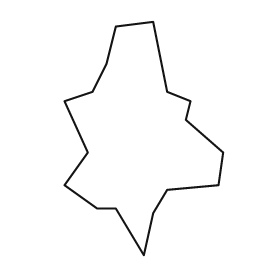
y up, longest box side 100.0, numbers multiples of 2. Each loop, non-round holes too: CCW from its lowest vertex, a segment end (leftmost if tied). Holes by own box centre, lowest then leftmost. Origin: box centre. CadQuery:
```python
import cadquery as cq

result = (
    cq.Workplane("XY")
    .moveTo(0.0, -50.0)
    .lineTo(4.0, -32.0)
    .lineTo(10.0, -22.0)
    .lineTo(32.0, -20.0)
    .lineTo(34.0, -6.0)
    .lineTo(18.0, 8.0)
    .lineTo(20.0, 16.0)
    .lineTo(10.0, 20.0)
    .lineTo(4.0, 50.0)
    .lineTo(-12.0, 48.0)
    .lineTo(-16.0, 32.0)
    .lineTo(-22.0, 20.0)
    .lineTo(-34.0, 16.0)
    .lineTo(-24.0, -6.0)
    .lineTo(-34.0, -20.0)
    .lineTo(-20.0, -30.0)
    .lineTo(-12.0, -30.0)
    .close()
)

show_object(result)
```